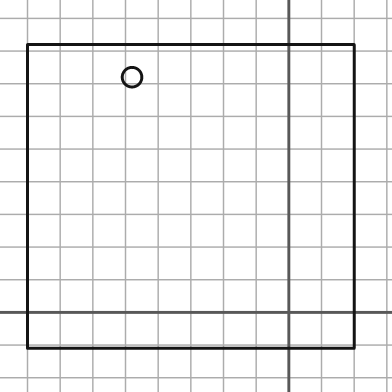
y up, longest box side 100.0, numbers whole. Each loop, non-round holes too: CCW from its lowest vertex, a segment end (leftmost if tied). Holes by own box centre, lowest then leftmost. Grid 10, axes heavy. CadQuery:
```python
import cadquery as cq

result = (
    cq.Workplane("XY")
    .moveTo(-80.0, -11.0)
    .lineTo(20.0, -11.0)
    .lineTo(20.0, 82.0)
    .lineTo(-80.0, 82.0)
    .close()
    .moveTo(-48.0, 72.0)
    .circle(3.0)
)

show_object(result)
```